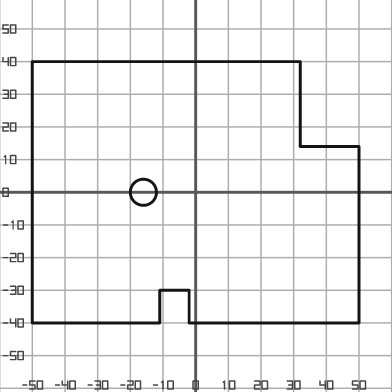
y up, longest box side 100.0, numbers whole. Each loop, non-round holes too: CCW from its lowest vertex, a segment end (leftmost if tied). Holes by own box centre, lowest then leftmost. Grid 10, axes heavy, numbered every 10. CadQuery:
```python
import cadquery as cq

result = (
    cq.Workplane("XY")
    .moveTo(-50.0, -40.0)
    .lineTo(-11.0, -40.0)
    .lineTo(-11.0, -30.0)
    .lineTo(-2.0, -30.0)
    .lineTo(-2.0, -40.0)
    .lineTo(50.0, -40.0)
    .lineTo(50.0, 14.0)
    .lineTo(32.0, 14.0)
    .lineTo(32.0, 40.0)
    .lineTo(-50.0, 40.0)
    .close()
    .moveTo(-16.0, 0.0)
    .circle(4.0)
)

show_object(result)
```